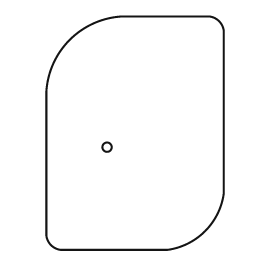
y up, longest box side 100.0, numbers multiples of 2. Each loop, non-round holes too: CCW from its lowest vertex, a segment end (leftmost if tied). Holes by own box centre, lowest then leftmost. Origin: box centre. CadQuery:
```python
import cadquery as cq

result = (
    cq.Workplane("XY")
    .moveTo(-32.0, -50.0)
    .lineTo(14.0, -50.0)
    .threePointArc((30.0, -42.0), (38.0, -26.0))
    .lineTo(38.0, 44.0)
    .threePointArc((36.0, 48.0), (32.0, 50.0))
    .lineTo(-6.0, 50.0)
    .threePointArc((-28.0, 40.0), (-38.0, 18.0))
    .lineTo(-38.0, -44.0)
    .threePointArc((-36.0, -48.0), (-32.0, -50.0))
    .close()
    .moveTo(-12.0, -6.0)
    .circle(2.0)
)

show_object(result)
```